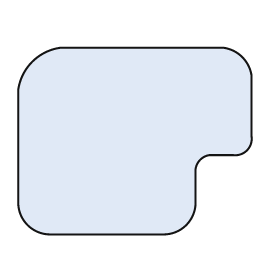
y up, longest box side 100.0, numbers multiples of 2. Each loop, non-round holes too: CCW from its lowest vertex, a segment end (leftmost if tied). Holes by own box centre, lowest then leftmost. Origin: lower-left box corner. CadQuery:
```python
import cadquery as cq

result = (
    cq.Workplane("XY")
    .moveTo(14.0, 0.0)
    .lineTo(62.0, 0.0)
    .threePointArc((72.0, 4.0), (76.0, 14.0))
    .lineTo(76.0, 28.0)
    .threePointArc((78.0, 32.0), (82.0, 34.0))
    .lineTo(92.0, 34.0)
    .threePointArc((98.0, 36.0), (100.0, 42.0))
    .lineTo(100.0, 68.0)
    .threePointArc((96.0, 76.0), (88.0, 80.0))
    .lineTo(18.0, 80.0)
    .threePointArc((6.0, 74.0), (0.0, 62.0))
    .lineTo(0.0, 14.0)
    .threePointArc((4.0, 4.0), (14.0, 0.0))
    .close()
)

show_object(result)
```